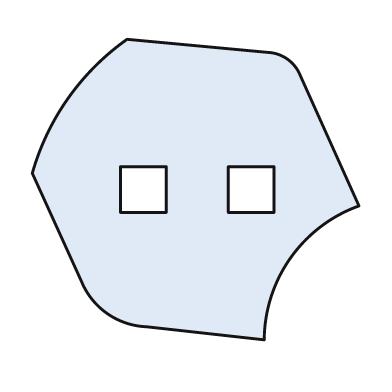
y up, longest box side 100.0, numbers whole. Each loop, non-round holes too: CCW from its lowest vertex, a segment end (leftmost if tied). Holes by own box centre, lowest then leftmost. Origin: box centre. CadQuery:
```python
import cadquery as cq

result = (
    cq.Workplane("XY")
    .moveTo(21.0, -46.0)
    .threePointArc((29.0, -21.0), (50.0, -5.0))
    .lineTo(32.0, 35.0)
    .threePointArc((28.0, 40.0), (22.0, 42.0))
    .lineTo(-21.0, 46.0)
    .threePointArc((-39.0, 28.0), (-50.0, 5.0))
    .lineTo(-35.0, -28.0)
    .threePointArc((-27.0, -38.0), (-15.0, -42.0))
    .close()
    .moveTo(-23.0, -7.0)
    .lineTo(-9.0, -7.0)
    .lineTo(-9.0, 7.0)
    .lineTo(-23.0, 7.0)
    .close()
    .moveTo(10.0, -7.0)
    .lineTo(24.0, -7.0)
    .lineTo(24.0, 7.0)
    .lineTo(10.0, 7.0)
    .close()
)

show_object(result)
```